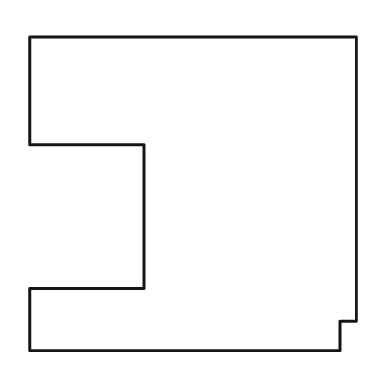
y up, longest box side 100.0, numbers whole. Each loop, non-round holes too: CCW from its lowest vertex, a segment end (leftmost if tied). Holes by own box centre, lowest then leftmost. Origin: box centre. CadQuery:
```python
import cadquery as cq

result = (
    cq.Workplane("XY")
    .moveTo(-50.0, -48.0)
    .lineTo(45.0, -48.0)
    .lineTo(45.0, -39.0)
    .lineTo(50.0, -39.0)
    .lineTo(50.0, 48.0)
    .lineTo(-50.0, 48.0)
    .lineTo(-50.0, 15.0)
    .lineTo(-15.0, 15.0)
    .lineTo(-15.0, -29.0)
    .lineTo(-50.0, -29.0)
    .close()
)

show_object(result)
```